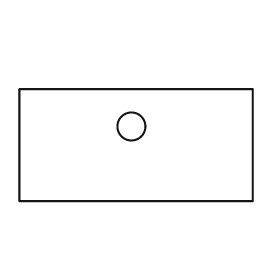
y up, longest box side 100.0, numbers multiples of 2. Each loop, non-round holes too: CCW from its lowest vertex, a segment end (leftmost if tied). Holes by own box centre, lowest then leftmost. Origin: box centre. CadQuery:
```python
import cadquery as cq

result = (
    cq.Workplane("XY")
    .moveTo(-50.0, -24.0)
    .lineTo(50.0, -24.0)
    .lineTo(50.0, 24.0)
    .lineTo(-50.0, 24.0)
    .close()
    .moveTo(-2.0, 8.0)
    .circle(6.0)
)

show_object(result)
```